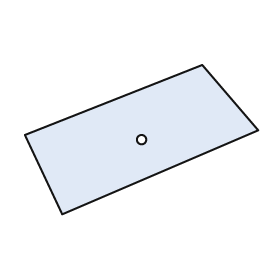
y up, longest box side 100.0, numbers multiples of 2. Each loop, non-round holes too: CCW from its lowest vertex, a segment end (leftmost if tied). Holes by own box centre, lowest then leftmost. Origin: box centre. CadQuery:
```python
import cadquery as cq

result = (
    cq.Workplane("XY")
    .moveTo(-34.0, -32.0)
    .lineTo(50.0, 4.0)
    .lineTo(26.0, 32.0)
    .lineTo(-50.0, 2.0)
    .close()
    .moveTo(0.0, 0.0)
    .circle(2.0)
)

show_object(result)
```